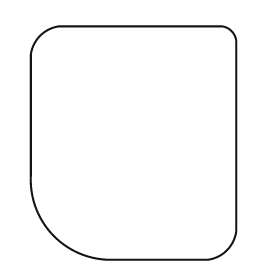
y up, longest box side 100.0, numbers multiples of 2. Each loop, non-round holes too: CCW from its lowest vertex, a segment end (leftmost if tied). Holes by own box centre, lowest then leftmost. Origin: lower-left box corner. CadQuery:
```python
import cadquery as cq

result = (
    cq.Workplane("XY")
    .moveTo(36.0, 0.0)
    .lineTo(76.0, 0.0)
    .threePointArc((84.0, 4.0), (88.0, 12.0))
    .lineTo(88.0, 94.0)
    .threePointArc((86.0, 98.0), (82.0, 100.0))
    .lineTo(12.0, 100.0)
    .threePointArc((4.0, 96.0), (0.0, 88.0))
    .lineTo(0.0, 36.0)
    .threePointArc((10.0, 10.0), (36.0, 0.0))
    .close()
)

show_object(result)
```